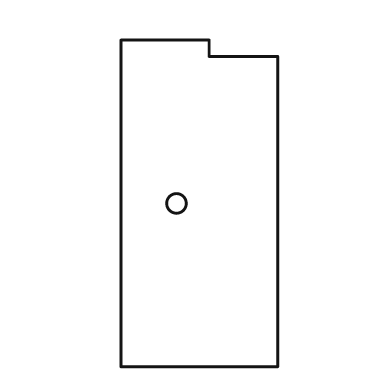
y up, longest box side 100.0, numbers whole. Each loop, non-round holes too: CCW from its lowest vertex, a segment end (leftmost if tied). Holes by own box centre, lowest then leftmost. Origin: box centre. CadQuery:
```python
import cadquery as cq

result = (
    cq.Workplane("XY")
    .moveTo(-24.0, -50.0)
    .lineTo(24.0, -50.0)
    .lineTo(24.0, 45.0)
    .lineTo(3.0, 45.0)
    .lineTo(3.0, 50.0)
    .lineTo(-24.0, 50.0)
    .close()
    .moveTo(-7.0, 0.0)
    .circle(3.0)
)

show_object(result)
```